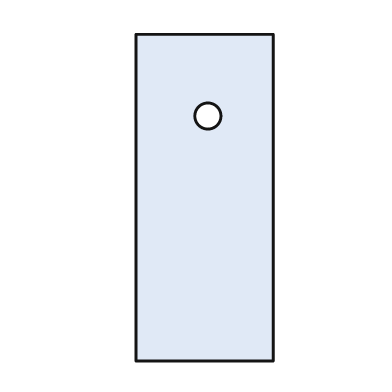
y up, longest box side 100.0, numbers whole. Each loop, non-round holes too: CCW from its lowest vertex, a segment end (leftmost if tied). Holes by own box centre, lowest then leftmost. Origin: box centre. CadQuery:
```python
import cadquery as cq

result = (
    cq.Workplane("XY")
    .moveTo(-21.0, -50.0)
    .lineTo(21.0, -50.0)
    .lineTo(21.0, 50.0)
    .lineTo(-21.0, 50.0)
    .close()
    .moveTo(1.0, 25.0)
    .circle(4.0)
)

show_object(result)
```